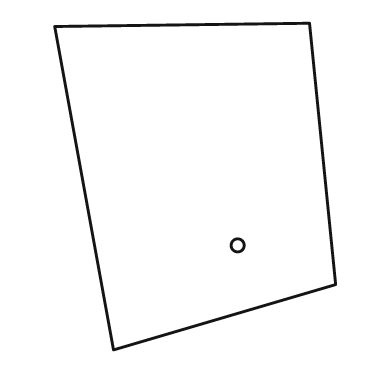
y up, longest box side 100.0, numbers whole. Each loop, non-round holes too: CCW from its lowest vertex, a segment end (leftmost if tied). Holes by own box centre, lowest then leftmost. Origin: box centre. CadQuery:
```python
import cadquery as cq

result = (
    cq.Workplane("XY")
    .moveTo(-25.0, -50.0)
    .lineTo(43.0, -30.0)
    .lineTo(35.0, 50.0)
    .lineTo(-43.0, 49.0)
    .close()
    .moveTo(13.0, -18.0)
    .circle(2.0)
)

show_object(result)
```